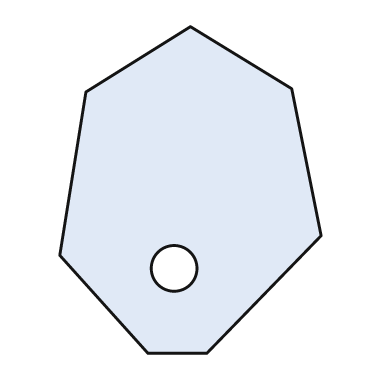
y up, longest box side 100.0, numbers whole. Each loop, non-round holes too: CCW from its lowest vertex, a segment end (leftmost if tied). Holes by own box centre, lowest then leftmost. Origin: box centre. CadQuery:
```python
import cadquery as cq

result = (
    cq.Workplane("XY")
    .moveTo(-13.0, -50.0)
    .lineTo(5.0, -50.0)
    .lineTo(40.0, -14.0)
    .lineTo(31.0, 31.0)
    .lineTo(0.0, 50.0)
    .lineTo(-32.0, 30.0)
    .lineTo(-40.0, -20.0)
    .close()
    .moveTo(-5.0, -24.0)
    .circle(7.0)
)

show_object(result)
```